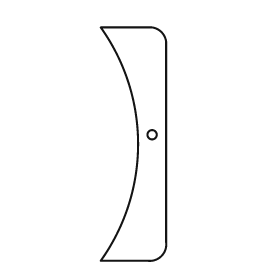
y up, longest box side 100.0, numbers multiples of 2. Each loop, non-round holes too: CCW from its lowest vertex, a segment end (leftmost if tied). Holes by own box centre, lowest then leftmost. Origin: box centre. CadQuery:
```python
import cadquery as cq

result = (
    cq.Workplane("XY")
    .moveTo(-14.0, -50.0)
    .lineTo(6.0, -50.0)
    .threePointArc((12.0, -48.0), (14.0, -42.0))
    .lineTo(14.0, 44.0)
    .threePointArc((12.0, 48.0), (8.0, 50.0))
    .lineTo(-14.0, 50.0)
    .threePointArc((2.0, 0.0), (-14.0, -50.0))
    .close()
    .moveTo(8.0, 4.0)
    .circle(2.0)
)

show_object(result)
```